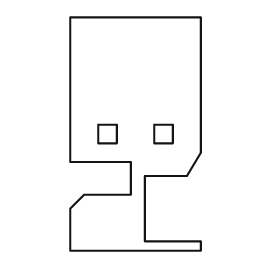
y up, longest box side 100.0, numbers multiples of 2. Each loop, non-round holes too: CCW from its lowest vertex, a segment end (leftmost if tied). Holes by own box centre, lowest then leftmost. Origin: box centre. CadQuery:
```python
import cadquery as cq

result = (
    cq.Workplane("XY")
    .moveTo(-28.0, -50.0)
    .lineTo(28.0, -50.0)
    .lineTo(28.0, -46.0)
    .lineTo(4.0, -46.0)
    .lineTo(4.0, -18.0)
    .lineTo(22.0, -18.0)
    .lineTo(28.0, -8.0)
    .lineTo(28.0, 50.0)
    .lineTo(-28.0, 50.0)
    .lineTo(-28.0, -12.0)
    .lineTo(-2.0, -12.0)
    .lineTo(-2.0, -26.0)
    .lineTo(-22.0, -26.0)
    .lineTo(-28.0, -32.0)
    .close()
    .moveTo(-16.0, -4.0)
    .lineTo(-8.0, -4.0)
    .lineTo(-8.0, 4.0)
    .lineTo(-16.0, 4.0)
    .close()
    .moveTo(8.0, -4.0)
    .lineTo(16.0, -4.0)
    .lineTo(16.0, 4.0)
    .lineTo(8.0, 4.0)
    .close()
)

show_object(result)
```